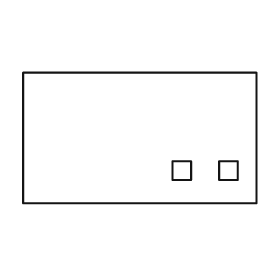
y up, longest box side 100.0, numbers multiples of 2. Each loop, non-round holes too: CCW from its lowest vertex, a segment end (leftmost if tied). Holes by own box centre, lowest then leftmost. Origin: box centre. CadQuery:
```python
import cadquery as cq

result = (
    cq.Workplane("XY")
    .moveTo(-50.0, -28.0)
    .lineTo(50.0, -28.0)
    .lineTo(50.0, 28.0)
    .lineTo(-50.0, 28.0)
    .close()
    .moveTo(14.0, -18.0)
    .lineTo(22.0, -18.0)
    .lineTo(22.0, -10.0)
    .lineTo(14.0, -10.0)
    .close()
    .moveTo(34.0, -18.0)
    .lineTo(42.0, -18.0)
    .lineTo(42.0, -10.0)
    .lineTo(34.0, -10.0)
    .close()
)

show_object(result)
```